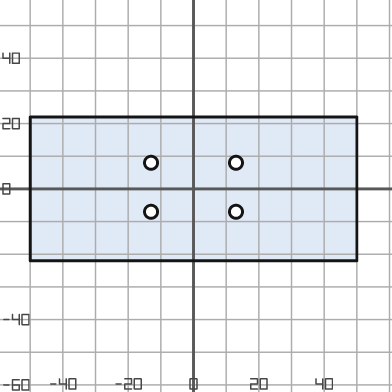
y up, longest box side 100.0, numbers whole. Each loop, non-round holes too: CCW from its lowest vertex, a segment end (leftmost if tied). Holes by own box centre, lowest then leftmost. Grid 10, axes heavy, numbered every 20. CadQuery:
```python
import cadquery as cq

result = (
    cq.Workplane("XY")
    .moveTo(-50.0, -22.0)
    .lineTo(50.0, -22.0)
    .lineTo(50.0, 22.0)
    .lineTo(-50.0, 22.0)
    .close()
    .moveTo(-13.0, -7.0)
    .circle(2.0)
    .moveTo(13.0, -7.0)
    .circle(2.0)
    .moveTo(-13.0, 8.0)
    .circle(2.0)
    .moveTo(13.0, 8.0)
    .circle(2.0)
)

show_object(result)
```